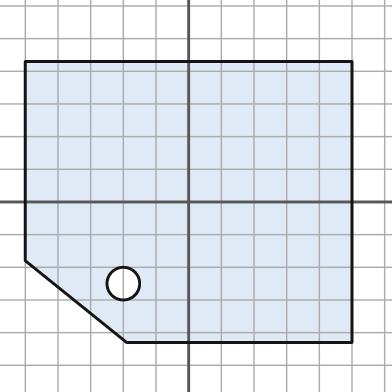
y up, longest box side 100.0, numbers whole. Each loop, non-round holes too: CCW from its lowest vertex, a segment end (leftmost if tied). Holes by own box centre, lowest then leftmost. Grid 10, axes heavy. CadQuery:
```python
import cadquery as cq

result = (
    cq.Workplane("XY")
    .moveTo(-19.0, -43.0)
    .lineTo(50.0, -43.0)
    .lineTo(50.0, 43.0)
    .lineTo(-50.0, 43.0)
    .lineTo(-50.0, -18.0)
    .close()
    .moveTo(-20.0, -25.0)
    .circle(5.0)
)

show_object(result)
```